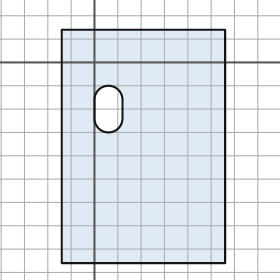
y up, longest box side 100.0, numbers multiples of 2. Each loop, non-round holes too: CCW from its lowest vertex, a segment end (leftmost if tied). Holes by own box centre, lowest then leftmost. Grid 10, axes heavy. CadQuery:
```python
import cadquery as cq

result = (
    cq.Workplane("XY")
    .moveTo(-14.0, -86.0)
    .lineTo(56.0, -86.0)
    .lineTo(56.0, 14.0)
    .lineTo(-14.0, 14.0)
    .close()
    .moveTo(0.0, -24.0)
    .threePointArc((6.0, -30.0), (12.0, -24.0))
    .lineTo(12.0, -16.0)
    .threePointArc((6.0, -10.0), (0.0, -16.0))
    .close()
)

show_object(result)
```